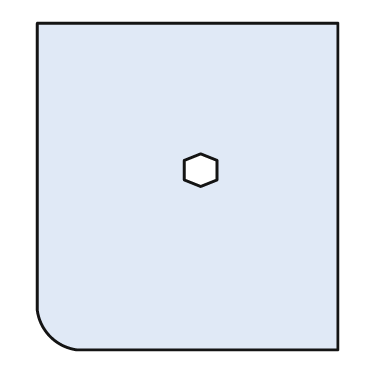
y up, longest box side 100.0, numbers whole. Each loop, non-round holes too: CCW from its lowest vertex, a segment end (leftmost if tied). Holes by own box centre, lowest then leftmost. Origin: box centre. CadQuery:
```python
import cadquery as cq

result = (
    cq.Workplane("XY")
    .moveTo(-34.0, -50.0)
    .lineTo(46.0, -50.0)
    .lineTo(46.0, 50.0)
    .lineTo(-46.0, 50.0)
    .lineTo(-46.0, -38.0)
    .threePointArc((-42.0, -46.0), (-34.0, -50.0))
    .close()
    .moveTo(4.0, 0.0)
    .lineTo(9.0, 2.0)
    .lineTo(9.0, 8.0)
    .lineTo(4.0, 10.0)
    .lineTo(-1.0, 8.0)
    .lineTo(-1.0, 2.0)
    .close()
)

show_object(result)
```